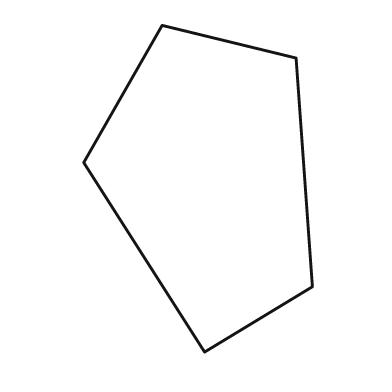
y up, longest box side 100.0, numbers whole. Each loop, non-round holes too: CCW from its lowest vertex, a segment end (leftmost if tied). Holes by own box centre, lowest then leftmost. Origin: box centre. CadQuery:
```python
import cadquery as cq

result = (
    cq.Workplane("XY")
    .moveTo(2.0, -50.0)
    .lineTo(35.0, -30.0)
    .lineTo(30.0, 40.0)
    .lineTo(-11.0, 50.0)
    .lineTo(-35.0, 8.0)
    .close()
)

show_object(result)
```